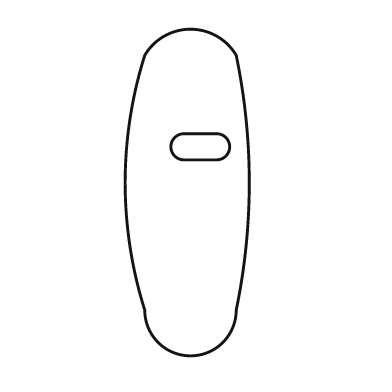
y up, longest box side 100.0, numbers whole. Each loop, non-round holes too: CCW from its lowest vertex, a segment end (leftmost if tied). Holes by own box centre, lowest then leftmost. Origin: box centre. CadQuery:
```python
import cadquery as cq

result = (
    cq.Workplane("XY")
    .moveTo(-13.0, -36.0)
    .threePointArc((1.0, -50.0), (15.0, -36.0))
    .threePointArc((19.0, 3.0), (15.0, 42.0))
    .threePointArc((1.0, 50.0), (-13.0, 42.0))
    .threePointArc((-19.0, 3.0), (-13.0, -36.0))
    .close()
    .moveTo(-1.0, 10.0)
    .lineTo(9.0, 10.0)
    .threePointArc((13.0, 14.0), (9.0, 18.0))
    .lineTo(-1.0, 18.0)
    .threePointArc((-5.0, 14.0), (-1.0, 10.0))
    .close()
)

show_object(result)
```